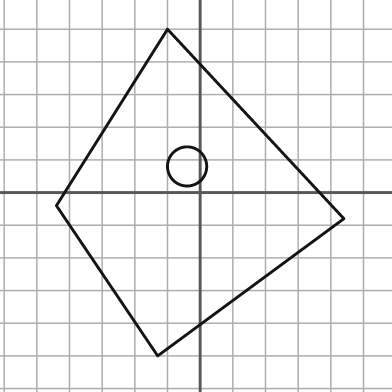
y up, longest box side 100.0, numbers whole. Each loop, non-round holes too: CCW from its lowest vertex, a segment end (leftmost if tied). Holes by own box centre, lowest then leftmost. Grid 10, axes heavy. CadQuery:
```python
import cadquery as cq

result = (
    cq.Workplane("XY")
    .moveTo(-13.0, -50.0)
    .lineTo(44.0, -8.0)
    .lineTo(-10.0, 50.0)
    .lineTo(-44.0, -4.0)
    .close()
    .moveTo(-4.0, 8.0)
    .circle(6.0)
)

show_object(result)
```